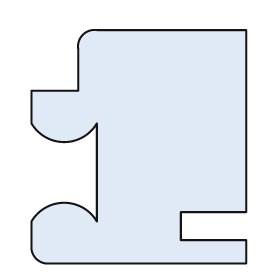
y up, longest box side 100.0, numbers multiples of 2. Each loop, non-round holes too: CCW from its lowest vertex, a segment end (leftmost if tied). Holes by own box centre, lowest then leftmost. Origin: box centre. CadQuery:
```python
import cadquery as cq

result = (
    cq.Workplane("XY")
    .moveTo(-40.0, -50.0)
    .lineTo(46.0, -50.0)
    .lineTo(46.0, -40.0)
    .lineTo(18.0, -40.0)
    .lineTo(18.0, -28.0)
    .lineTo(46.0, -28.0)
    .lineTo(46.0, 50.0)
    .lineTo(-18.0, 50.0)
    .threePointArc((-24.0, 48.0), (-26.0, 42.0))
    .lineTo(-26.0, 24.0)
    .lineTo(-46.0, 24.0)
    .lineTo(-46.0, 10.0)
    .threePointArc((-32.0, 2.0), (-18.0, 10.0))
    .lineTo(-18.0, -32.0)
    .threePointArc((-32.0, -24.0), (-46.0, -32.0))
    .lineTo(-46.0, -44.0)
    .threePointArc((-44.0, -48.0), (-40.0, -50.0))
    .close()
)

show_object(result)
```